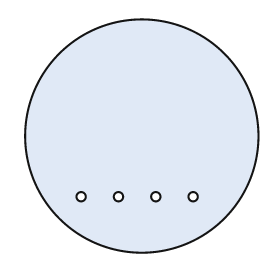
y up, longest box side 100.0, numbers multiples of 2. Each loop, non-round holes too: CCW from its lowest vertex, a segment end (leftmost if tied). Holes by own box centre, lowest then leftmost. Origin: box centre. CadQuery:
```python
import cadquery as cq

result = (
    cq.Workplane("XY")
    .moveTo(0.0, 0.0)
    .circle(50.0)
    .moveTo(-26.0, -26.0)
    .circle(2.0)
    .moveTo(-10.0, -26.0)
    .circle(2.0)
    .moveTo(6.0, -26.0)
    .circle(2.0)
    .moveTo(22.0, -26.0)
    .circle(2.0)
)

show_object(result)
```